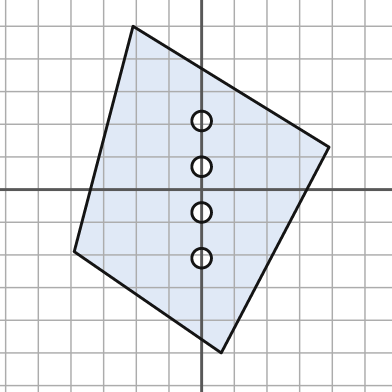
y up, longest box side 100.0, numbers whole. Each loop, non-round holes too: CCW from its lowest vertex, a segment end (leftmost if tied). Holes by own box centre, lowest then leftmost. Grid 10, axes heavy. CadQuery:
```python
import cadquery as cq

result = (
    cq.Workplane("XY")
    .moveTo(6.0, -50.0)
    .lineTo(39.0, 13.0)
    .lineTo(-21.0, 50.0)
    .lineTo(-39.0, -19.0)
    .close()
    .moveTo(0.0, -21.0)
    .circle(3.0)
    .moveTo(0.0, -7.0)
    .circle(3.0)
    .moveTo(0.0, 7.0)
    .circle(3.0)
    .moveTo(0.0, 21.0)
    .circle(3.0)
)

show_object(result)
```